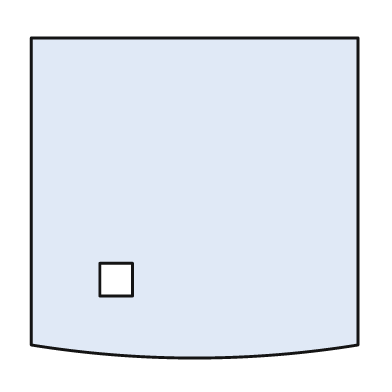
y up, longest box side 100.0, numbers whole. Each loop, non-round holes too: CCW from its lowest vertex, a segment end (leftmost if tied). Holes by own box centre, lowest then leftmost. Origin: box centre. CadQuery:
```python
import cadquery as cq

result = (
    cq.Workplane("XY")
    .moveTo(-50.0, -45.0)
    .threePointArc((0.0, -49.0), (50.0, -45.0))
    .lineTo(50.0, 49.0)
    .lineTo(-50.0, 49.0)
    .close()
    .moveTo(-29.0, -30.0)
    .lineTo(-19.0, -30.0)
    .lineTo(-19.0, -20.0)
    .lineTo(-29.0, -20.0)
    .close()
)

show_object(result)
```